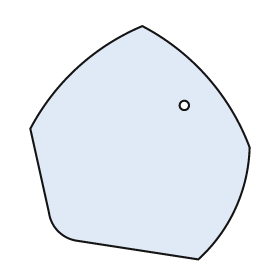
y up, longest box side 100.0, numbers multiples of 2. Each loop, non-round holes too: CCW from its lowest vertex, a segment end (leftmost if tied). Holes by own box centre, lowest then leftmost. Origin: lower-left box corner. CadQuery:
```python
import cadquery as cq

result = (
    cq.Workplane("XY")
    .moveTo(72.0, 0.0)
    .threePointArc((88.0, 22.0), (94.0, 48.0))
    .threePointArc((76.0, 78.0), (48.0, 100.0))
    .threePointArc((20.0, 82.0), (0.0, 56.0))
    .lineTo(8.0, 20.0)
    .threePointArc((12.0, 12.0), (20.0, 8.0))
    .close()
    .moveTo(66.0, 66.0)
    .circle(2.0)
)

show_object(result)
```